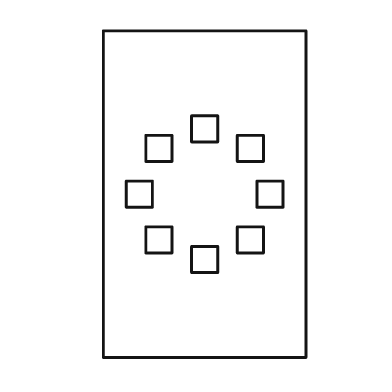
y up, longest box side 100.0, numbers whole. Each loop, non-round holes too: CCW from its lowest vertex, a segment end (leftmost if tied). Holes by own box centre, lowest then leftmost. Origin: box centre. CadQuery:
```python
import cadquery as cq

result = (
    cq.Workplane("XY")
    .moveTo(-31.0, -50.0)
    .lineTo(31.0, -50.0)
    .lineTo(31.0, 50.0)
    .lineTo(-31.0, 50.0)
    .close()
    .moveTo(-4.0, -24.0)
    .lineTo(4.0, -24.0)
    .lineTo(4.0, -16.0)
    .lineTo(-4.0, -16.0)
    .close()
    .moveTo(-18.0, -18.0)
    .lineTo(-10.0, -18.0)
    .lineTo(-10.0, -10.0)
    .lineTo(-18.0, -10.0)
    .close()
    .moveTo(10.0, -18.0)
    .lineTo(18.0, -18.0)
    .lineTo(18.0, -10.0)
    .lineTo(10.0, -10.0)
    .close()
    .moveTo(-24.0, -4.0)
    .lineTo(-16.0, -4.0)
    .lineTo(-16.0, 4.0)
    .lineTo(-24.0, 4.0)
    .close()
    .moveTo(16.0, -4.0)
    .lineTo(24.0, -4.0)
    .lineTo(24.0, 4.0)
    .lineTo(16.0, 4.0)
    .close()
    .moveTo(-18.0, 10.0)
    .lineTo(-10.0, 10.0)
    .lineTo(-10.0, 18.0)
    .lineTo(-18.0, 18.0)
    .close()
    .moveTo(10.0, 10.0)
    .lineTo(18.0, 10.0)
    .lineTo(18.0, 18.0)
    .lineTo(10.0, 18.0)
    .close()
    .moveTo(-4.0, 16.0)
    .lineTo(4.0, 16.0)
    .lineTo(4.0, 24.0)
    .lineTo(-4.0, 24.0)
    .close()
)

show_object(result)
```